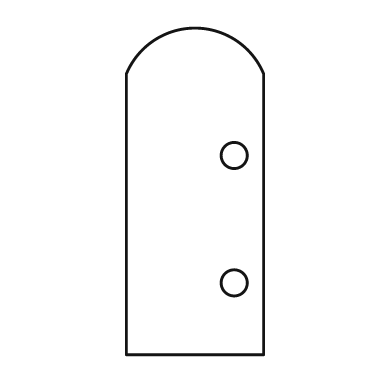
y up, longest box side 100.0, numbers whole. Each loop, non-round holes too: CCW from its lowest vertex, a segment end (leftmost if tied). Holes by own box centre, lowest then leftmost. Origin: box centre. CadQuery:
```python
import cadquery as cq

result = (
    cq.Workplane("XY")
    .moveTo(-21.0, -50.0)
    .lineTo(21.0, -50.0)
    .lineTo(21.0, 36.0)
    .threePointArc((0.0, 50.0), (-21.0, 36.0))
    .close()
    .moveTo(12.0, -28.0)
    .circle(4.0)
    .moveTo(12.0, 11.0)
    .circle(4.0)
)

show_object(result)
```